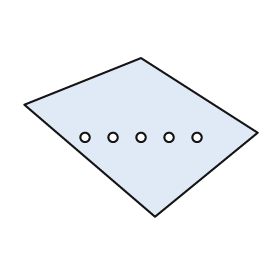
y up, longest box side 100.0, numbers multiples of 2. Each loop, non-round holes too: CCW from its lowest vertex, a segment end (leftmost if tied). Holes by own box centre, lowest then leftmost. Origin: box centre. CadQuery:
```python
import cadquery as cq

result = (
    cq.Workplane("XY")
    .moveTo(6.0, -34.0)
    .lineTo(50.0, 2.0)
    .lineTo(0.0, 34.0)
    .lineTo(-50.0, 14.0)
    .close()
    .moveTo(-24.0, 0.0)
    .circle(2.0)
    .moveTo(-12.0, 0.0)
    .circle(2.0)
    .moveTo(0.0, 0.0)
    .circle(2.0)
    .moveTo(12.0, 0.0)
    .circle(2.0)
    .moveTo(24.0, 0.0)
    .circle(2.0)
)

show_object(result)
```